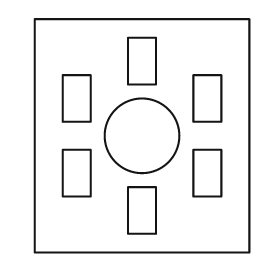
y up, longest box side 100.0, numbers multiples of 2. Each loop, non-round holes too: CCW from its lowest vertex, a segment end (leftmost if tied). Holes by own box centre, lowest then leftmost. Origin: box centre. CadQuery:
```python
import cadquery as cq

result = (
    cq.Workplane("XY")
    .moveTo(-46.0, -50.0)
    .lineTo(46.0, -50.0)
    .lineTo(46.0, 50.0)
    .lineTo(-46.0, 50.0)
    .close()
    .moveTo(-6.0, -42.0)
    .lineTo(6.0, -42.0)
    .lineTo(6.0, -22.0)
    .lineTo(-6.0, -22.0)
    .close()
    .moveTo(-34.0, -26.0)
    .lineTo(-22.0, -26.0)
    .lineTo(-22.0, -6.0)
    .lineTo(-34.0, -6.0)
    .close()
    .moveTo(22.0, -26.0)
    .lineTo(34.0, -26.0)
    .lineTo(34.0, -6.0)
    .lineTo(22.0, -6.0)
    .close()
    .moveTo(0.0, 0.0)
    .circle(16.0)
    .moveTo(-34.0, 6.0)
    .lineTo(-22.0, 6.0)
    .lineTo(-22.0, 26.0)
    .lineTo(-34.0, 26.0)
    .close()
    .moveTo(22.0, 6.0)
    .lineTo(34.0, 6.0)
    .lineTo(34.0, 26.0)
    .lineTo(22.0, 26.0)
    .close()
    .moveTo(-6.0, 22.0)
    .lineTo(6.0, 22.0)
    .lineTo(6.0, 42.0)
    .lineTo(-6.0, 42.0)
    .close()
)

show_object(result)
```